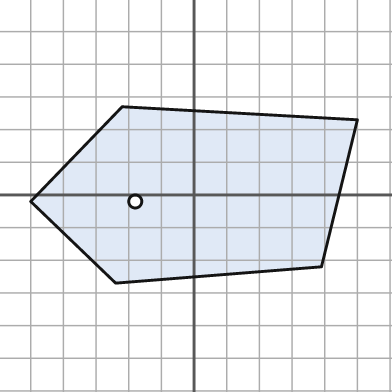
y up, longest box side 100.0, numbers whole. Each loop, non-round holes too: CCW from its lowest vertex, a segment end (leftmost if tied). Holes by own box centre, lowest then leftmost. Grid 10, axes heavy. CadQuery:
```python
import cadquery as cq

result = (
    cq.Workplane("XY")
    .moveTo(-24.0, -27.0)
    .lineTo(39.0, -22.0)
    .lineTo(50.0, 23.0)
    .lineTo(-22.0, 27.0)
    .lineTo(-50.0, -2.0)
    .close()
    .moveTo(-18.0, -2.0)
    .circle(2.0)
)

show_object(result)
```